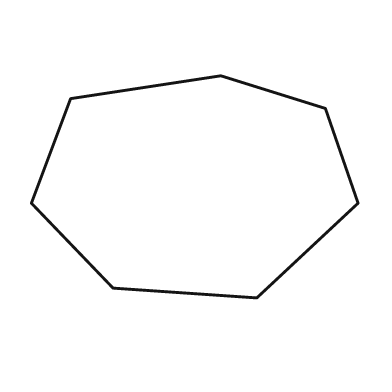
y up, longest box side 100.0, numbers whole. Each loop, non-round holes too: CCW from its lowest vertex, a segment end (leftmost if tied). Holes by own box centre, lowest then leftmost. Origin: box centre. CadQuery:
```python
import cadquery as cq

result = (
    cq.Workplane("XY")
    .moveTo(19.0, -34.0)
    .lineTo(50.0, -5.0)
    .lineTo(40.0, 24.0)
    .lineTo(8.0, 34.0)
    .lineTo(-38.0, 27.0)
    .lineTo(-50.0, -5.0)
    .lineTo(-25.0, -31.0)
    .close()
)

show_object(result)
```